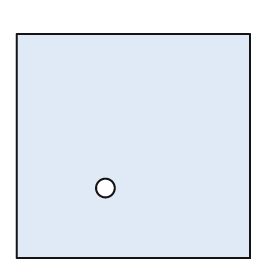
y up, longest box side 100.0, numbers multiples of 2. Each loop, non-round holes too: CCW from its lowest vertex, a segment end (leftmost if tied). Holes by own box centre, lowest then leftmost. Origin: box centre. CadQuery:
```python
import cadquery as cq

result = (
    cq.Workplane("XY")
    .moveTo(-50.0, -48.0)
    .lineTo(50.0, -48.0)
    .lineTo(50.0, 48.0)
    .lineTo(-50.0, 48.0)
    .close()
    .moveTo(-12.0, -18.0)
    .circle(4.0)
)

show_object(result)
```